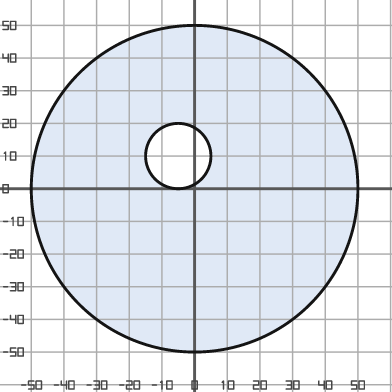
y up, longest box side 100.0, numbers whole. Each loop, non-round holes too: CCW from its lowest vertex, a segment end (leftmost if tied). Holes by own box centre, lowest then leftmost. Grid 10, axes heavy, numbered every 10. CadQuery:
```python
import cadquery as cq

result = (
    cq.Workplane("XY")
    .moveTo(0.0, 0.0)
    .circle(50.0)
    .moveTo(-5.0, 10.0)
    .circle(10.0)
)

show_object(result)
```